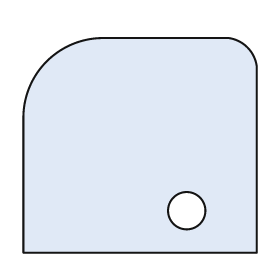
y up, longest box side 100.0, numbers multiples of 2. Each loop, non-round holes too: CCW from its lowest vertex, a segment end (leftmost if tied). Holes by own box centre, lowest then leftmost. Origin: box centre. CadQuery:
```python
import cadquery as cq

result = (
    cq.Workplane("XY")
    .moveTo(-50.0, -46.0)
    .lineTo(50.0, -46.0)
    .lineTo(50.0, 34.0)
    .threePointArc((46.0, 42.0), (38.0, 46.0))
    .lineTo(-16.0, 46.0)
    .threePointArc((-40.0, 36.0), (-50.0, 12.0))
    .close()
    .moveTo(20.0, -28.0)
    .circle(8.0)
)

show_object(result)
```